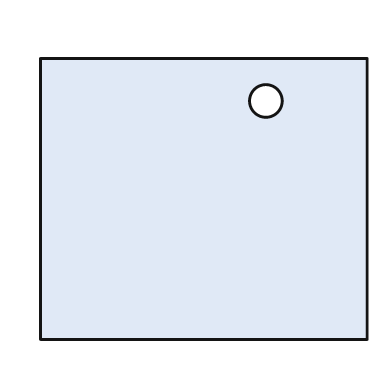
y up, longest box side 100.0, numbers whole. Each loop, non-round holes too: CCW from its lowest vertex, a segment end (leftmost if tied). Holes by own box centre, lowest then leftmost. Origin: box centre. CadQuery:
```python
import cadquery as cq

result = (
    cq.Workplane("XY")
    .moveTo(-50.0, -43.0)
    .lineTo(50.0, -43.0)
    .lineTo(50.0, 43.0)
    .lineTo(-50.0, 43.0)
    .close()
    .moveTo(19.0, 30.0)
    .circle(5.0)
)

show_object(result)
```